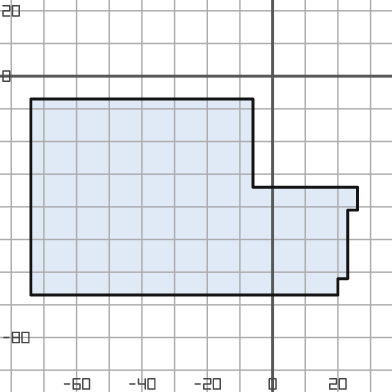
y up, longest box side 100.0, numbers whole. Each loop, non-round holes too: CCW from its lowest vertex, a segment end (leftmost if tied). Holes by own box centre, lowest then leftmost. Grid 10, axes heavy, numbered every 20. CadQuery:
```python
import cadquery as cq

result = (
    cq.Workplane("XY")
    .moveTo(-74.0, -67.0)
    .lineTo(20.0, -67.0)
    .lineTo(20.0, -62.0)
    .lineTo(23.0, -62.0)
    .lineTo(23.0, -41.0)
    .lineTo(26.0, -41.0)
    .lineTo(26.0, -34.0)
    .lineTo(-6.0, -34.0)
    .lineTo(-6.0, -7.0)
    .lineTo(-74.0, -7.0)
    .close()
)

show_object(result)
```